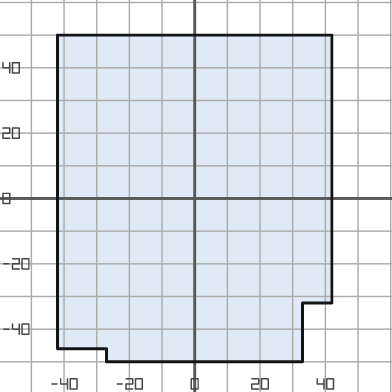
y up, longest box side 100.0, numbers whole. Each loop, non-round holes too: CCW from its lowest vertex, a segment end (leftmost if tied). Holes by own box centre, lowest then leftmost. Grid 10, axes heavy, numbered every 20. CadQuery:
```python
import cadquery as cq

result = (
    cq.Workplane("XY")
    .moveTo(-27.0, -50.0)
    .lineTo(33.0, -50.0)
    .lineTo(33.0, -32.0)
    .lineTo(42.0, -32.0)
    .lineTo(42.0, 50.0)
    .lineTo(-42.0, 50.0)
    .lineTo(-42.0, -46.0)
    .lineTo(-27.0, -46.0)
    .close()
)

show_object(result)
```